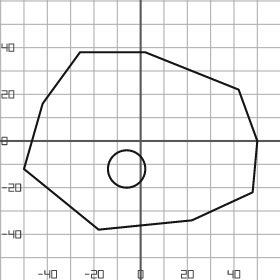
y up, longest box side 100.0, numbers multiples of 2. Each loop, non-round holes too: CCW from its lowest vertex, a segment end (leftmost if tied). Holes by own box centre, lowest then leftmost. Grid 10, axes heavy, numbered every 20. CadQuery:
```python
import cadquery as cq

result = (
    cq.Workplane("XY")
    .moveTo(-18.0, -38.0)
    .lineTo(22.0, -34.0)
    .lineTo(48.0, -22.0)
    .lineTo(50.0, 0.0)
    .lineTo(42.0, 22.0)
    .lineTo(2.0, 38.0)
    .lineTo(-26.0, 38.0)
    .lineTo(-42.0, 16.0)
    .lineTo(-50.0, -12.0)
    .close()
    .moveTo(-6.0, -12.0)
    .circle(8.0)
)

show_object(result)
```